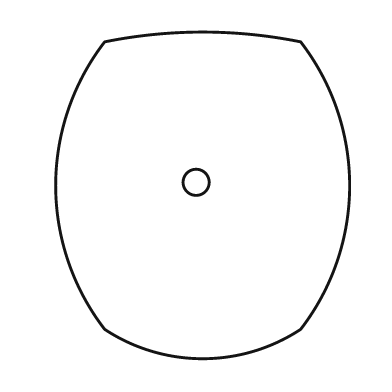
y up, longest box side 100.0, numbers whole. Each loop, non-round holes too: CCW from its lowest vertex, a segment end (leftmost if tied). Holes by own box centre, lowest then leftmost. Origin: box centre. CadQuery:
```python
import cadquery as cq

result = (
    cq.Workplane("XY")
    .moveTo(-30.0, -41.0)
    .threePointArc((0.0, -50.0), (30.0, -41.0))
    .threePointArc((45.0, 3.0), (30.0, 47.0))
    .threePointArc((0.0, 50.0), (-30.0, 47.0))
    .threePointArc((-45.0, 3.0), (-30.0, -41.0))
    .close()
    .moveTo(-2.0, 4.0)
    .circle(4.0)
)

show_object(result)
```